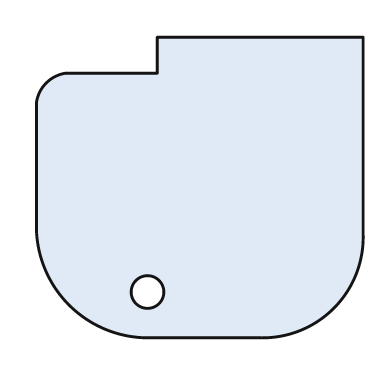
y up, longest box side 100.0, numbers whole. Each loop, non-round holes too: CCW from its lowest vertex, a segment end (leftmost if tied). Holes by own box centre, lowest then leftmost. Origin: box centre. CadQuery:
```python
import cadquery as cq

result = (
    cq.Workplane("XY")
    .moveTo(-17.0, -46.0)
    .lineTo(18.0, -46.0)
    .threePointArc((41.0, -37.0), (50.0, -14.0))
    .lineTo(50.0, 46.0)
    .lineTo(-13.0, 46.0)
    .lineTo(-13.0, 35.0)
    .lineTo(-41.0, 35.0)
    .threePointArc((-47.0, 32.0), (-50.0, 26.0))
    .lineTo(-50.0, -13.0)
    .threePointArc((-40.0, -36.0), (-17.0, -46.0))
    .close()
    .moveTo(-16.0, -32.0)
    .circle(5.0)
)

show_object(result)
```